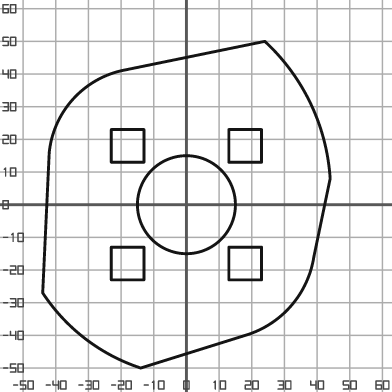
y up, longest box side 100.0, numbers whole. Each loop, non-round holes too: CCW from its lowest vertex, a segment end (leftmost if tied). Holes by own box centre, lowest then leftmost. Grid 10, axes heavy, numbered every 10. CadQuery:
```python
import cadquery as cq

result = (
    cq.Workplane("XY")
    .moveTo(-14.0, -50.0)
    .lineTo(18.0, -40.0)
    .threePointArc((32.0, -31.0), (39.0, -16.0))
    .lineTo(44.0, 8.0)
    .threePointArc((38.0, 31.0), (24.0, 50.0))
    .lineTo(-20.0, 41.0)
    .threePointArc((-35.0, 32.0), (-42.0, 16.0))
    .lineTo(-44.0, -27.0)
    .threePointArc((-31.0, -41.0), (-14.0, -50.0))
    .close()
    .moveTo(-23.0, -23.0)
    .lineTo(-13.0, -23.0)
    .lineTo(-13.0, -13.0)
    .lineTo(-23.0, -13.0)
    .close()
    .moveTo(13.0, -23.0)
    .lineTo(23.0, -23.0)
    .lineTo(23.0, -13.0)
    .lineTo(13.0, -13.0)
    .close()
    .moveTo(0.0, 0.0)
    .circle(15.0)
    .moveTo(-23.0, 13.0)
    .lineTo(-13.0, 13.0)
    .lineTo(-13.0, 23.0)
    .lineTo(-23.0, 23.0)
    .close()
    .moveTo(13.0, 13.0)
    .lineTo(23.0, 13.0)
    .lineTo(23.0, 23.0)
    .lineTo(13.0, 23.0)
    .close()
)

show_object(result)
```